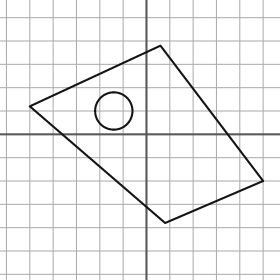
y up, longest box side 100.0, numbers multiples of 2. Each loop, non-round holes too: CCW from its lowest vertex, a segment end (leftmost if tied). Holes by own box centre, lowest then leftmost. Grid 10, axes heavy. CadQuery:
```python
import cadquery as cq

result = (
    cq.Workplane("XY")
    .moveTo(8.0, -38.0)
    .lineTo(50.0, -20.0)
    .lineTo(6.0, 38.0)
    .lineTo(-50.0, 12.0)
    .close()
    .moveTo(-14.0, 10.0)
    .circle(8.0)
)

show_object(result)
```